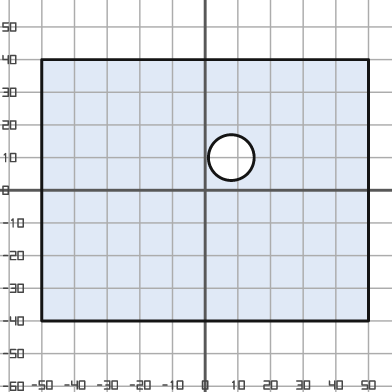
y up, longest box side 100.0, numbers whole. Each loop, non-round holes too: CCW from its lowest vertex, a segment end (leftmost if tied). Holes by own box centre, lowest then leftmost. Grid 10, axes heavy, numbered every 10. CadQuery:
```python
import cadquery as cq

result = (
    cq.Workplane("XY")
    .moveTo(-50.0, -40.0)
    .lineTo(50.0, -40.0)
    .lineTo(50.0, 40.0)
    .lineTo(-50.0, 40.0)
    .close()
    .moveTo(8.0, 10.0)
    .circle(7.0)
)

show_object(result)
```